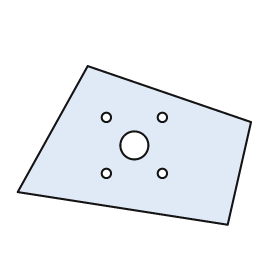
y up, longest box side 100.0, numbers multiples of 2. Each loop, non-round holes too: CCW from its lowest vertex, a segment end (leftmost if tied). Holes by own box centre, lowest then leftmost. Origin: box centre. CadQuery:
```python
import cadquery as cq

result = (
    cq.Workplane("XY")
    .moveTo(40.0, -34.0)
    .lineTo(50.0, 10.0)
    .lineTo(-20.0, 34.0)
    .lineTo(-50.0, -20.0)
    .close()
    .moveTo(-12.0, -12.0)
    .circle(2.0)
    .moveTo(12.0, -12.0)
    .circle(2.0)
    .moveTo(0.0, 0.0)
    .circle(6.0)
    .moveTo(-12.0, 12.0)
    .circle(2.0)
    .moveTo(12.0, 12.0)
    .circle(2.0)
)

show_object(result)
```